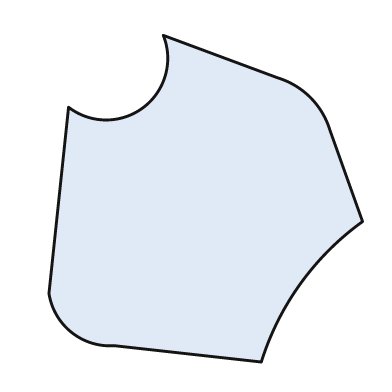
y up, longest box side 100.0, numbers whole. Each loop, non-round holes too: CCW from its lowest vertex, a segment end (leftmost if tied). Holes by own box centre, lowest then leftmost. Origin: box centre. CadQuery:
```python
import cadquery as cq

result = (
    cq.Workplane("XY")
    .moveTo(17.0, -50.0)
    .threePointArc((29.0, -26.0), (48.0, -7.0))
    .lineTo(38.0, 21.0)
    .threePointArc((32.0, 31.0), (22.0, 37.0))
    .lineTo(-13.0, 50.0)
    .threePointArc((-19.0, 28.0), (-42.0, 28.0))
    .lineTo(-48.0, -29.0)
    .threePointArc((-41.0, -41.0), (-28.0, -45.0))
    .close()
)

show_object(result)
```